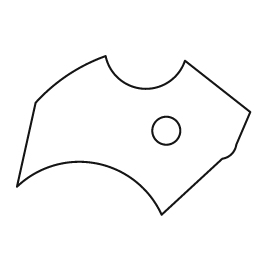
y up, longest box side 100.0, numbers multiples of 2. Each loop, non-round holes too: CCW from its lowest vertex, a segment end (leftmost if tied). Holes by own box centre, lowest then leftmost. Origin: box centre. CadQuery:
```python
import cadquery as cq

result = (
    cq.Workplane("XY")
    .moveTo(12.0, -34.0)
    .lineTo(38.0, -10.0)
    .threePointArc((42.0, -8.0), (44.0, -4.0))
    .lineTo(50.0, 10.0)
    .lineTo(22.0, 32.0)
    .threePointArc((4.0, 20.0), (-12.0, 34.0))
    .threePointArc((-28.0, 26.0), (-42.0, 14.0))
    .lineTo(-50.0, -22.0)
    .threePointArc((-16.0, -12.0), (12.0, -34.0))
    .close()
    .moveTo(14.0, 2.0)
    .circle(6.0)
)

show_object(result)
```